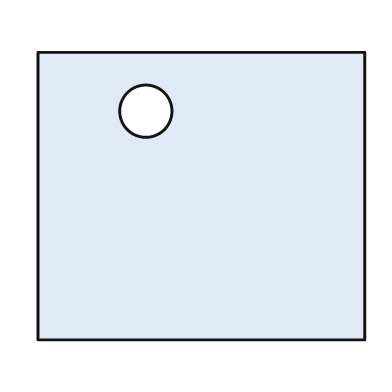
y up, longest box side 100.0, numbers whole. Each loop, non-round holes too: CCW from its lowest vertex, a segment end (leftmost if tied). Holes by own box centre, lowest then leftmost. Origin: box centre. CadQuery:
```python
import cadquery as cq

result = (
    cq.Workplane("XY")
    .moveTo(-50.0, -44.0)
    .lineTo(50.0, -44.0)
    .lineTo(50.0, 44.0)
    .lineTo(-50.0, 44.0)
    .close()
    .moveTo(-17.0, 26.0)
    .circle(8.0)
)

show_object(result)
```